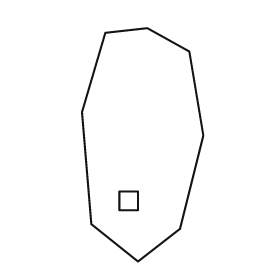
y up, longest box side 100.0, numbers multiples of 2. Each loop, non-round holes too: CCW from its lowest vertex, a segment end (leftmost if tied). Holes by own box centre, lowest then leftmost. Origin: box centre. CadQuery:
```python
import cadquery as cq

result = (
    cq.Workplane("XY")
    .moveTo(-2.0, -50.0)
    .lineTo(16.0, -36.0)
    .lineTo(26.0, 4.0)
    .lineTo(20.0, 40.0)
    .lineTo(2.0, 50.0)
    .lineTo(-16.0, 48.0)
    .lineTo(-26.0, 14.0)
    .lineTo(-22.0, -34.0)
    .close()
    .moveTo(-10.0, -28.0)
    .lineTo(-2.0, -28.0)
    .lineTo(-2.0, -20.0)
    .lineTo(-10.0, -20.0)
    .close()
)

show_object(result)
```